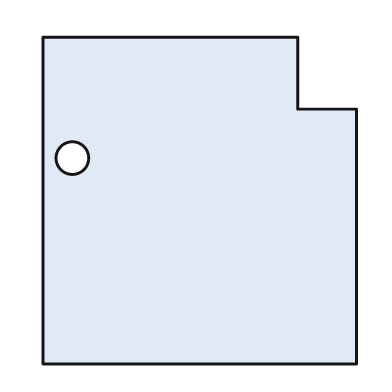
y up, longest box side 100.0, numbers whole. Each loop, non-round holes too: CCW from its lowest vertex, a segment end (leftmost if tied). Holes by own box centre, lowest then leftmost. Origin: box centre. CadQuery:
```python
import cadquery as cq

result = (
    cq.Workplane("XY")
    .moveTo(-48.0, -50.0)
    .lineTo(48.0, -50.0)
    .lineTo(48.0, 28.0)
    .lineTo(30.0, 28.0)
    .lineTo(30.0, 50.0)
    .lineTo(-48.0, 50.0)
    .close()
    .moveTo(-39.0, 13.0)
    .circle(5.0)
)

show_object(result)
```